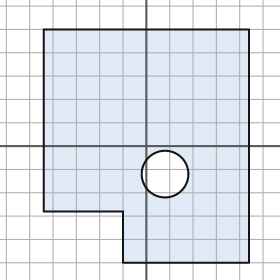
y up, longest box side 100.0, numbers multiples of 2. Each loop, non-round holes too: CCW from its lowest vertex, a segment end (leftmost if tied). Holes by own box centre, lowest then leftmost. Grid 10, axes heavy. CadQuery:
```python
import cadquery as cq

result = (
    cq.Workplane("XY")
    .moveTo(-10.0, -50.0)
    .lineTo(44.0, -50.0)
    .lineTo(44.0, 50.0)
    .lineTo(-44.0, 50.0)
    .lineTo(-44.0, -28.0)
    .lineTo(-10.0, -28.0)
    .close()
    .moveTo(8.0, -12.0)
    .circle(10.0)
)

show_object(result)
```